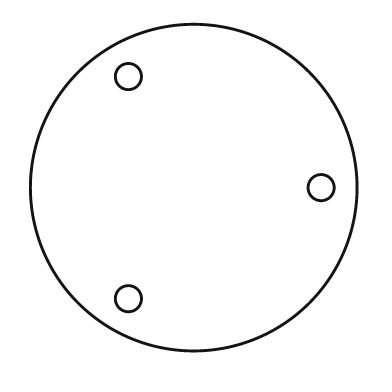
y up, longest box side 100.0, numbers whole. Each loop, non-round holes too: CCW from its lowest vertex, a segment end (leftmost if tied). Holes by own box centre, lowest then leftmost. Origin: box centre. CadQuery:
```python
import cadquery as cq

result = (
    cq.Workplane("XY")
    .moveTo(0.0, 0.0)
    .circle(50.0)
    .moveTo(-20.0, -34.0)
    .circle(4.0)
    .moveTo(39.0, 0.0)
    .circle(4.0)
    .moveTo(-20.0, 34.0)
    .circle(4.0)
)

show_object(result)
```